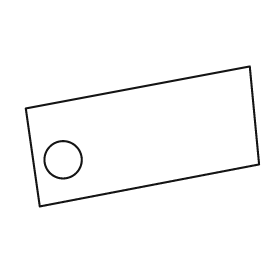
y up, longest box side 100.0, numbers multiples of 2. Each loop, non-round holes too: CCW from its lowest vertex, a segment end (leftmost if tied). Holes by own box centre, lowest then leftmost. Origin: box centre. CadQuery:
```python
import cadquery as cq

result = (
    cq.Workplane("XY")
    .moveTo(-44.0, -30.0)
    .lineTo(50.0, -12.0)
    .lineTo(46.0, 30.0)
    .lineTo(-50.0, 12.0)
    .close()
    .moveTo(-34.0, -10.0)
    .circle(8.0)
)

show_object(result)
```